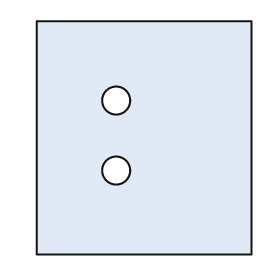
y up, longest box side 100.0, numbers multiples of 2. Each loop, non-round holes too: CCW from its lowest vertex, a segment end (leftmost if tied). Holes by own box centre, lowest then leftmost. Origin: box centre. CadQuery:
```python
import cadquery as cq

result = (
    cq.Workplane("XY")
    .moveTo(-46.0, -50.0)
    .lineTo(46.0, -50.0)
    .lineTo(46.0, 50.0)
    .lineTo(-46.0, 50.0)
    .close()
    .moveTo(-12.0, -14.0)
    .circle(6.0)
    .moveTo(-12.0, 16.0)
    .circle(6.0)
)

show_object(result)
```